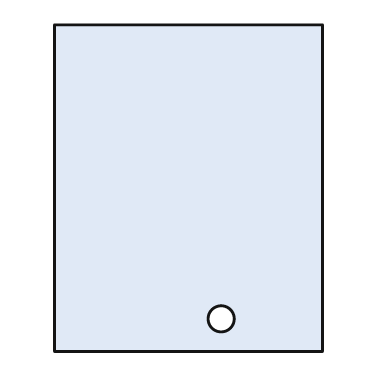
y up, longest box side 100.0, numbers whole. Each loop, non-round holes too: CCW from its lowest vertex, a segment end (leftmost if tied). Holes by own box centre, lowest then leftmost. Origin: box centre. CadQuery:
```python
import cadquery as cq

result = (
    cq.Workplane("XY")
    .moveTo(-41.0, -50.0)
    .lineTo(41.0, -50.0)
    .lineTo(41.0, 50.0)
    .lineTo(-41.0, 50.0)
    .close()
    .moveTo(10.0, -40.0)
    .circle(4.0)
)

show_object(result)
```